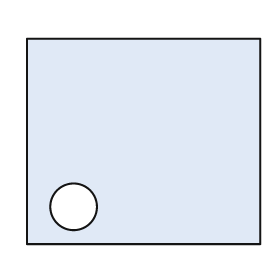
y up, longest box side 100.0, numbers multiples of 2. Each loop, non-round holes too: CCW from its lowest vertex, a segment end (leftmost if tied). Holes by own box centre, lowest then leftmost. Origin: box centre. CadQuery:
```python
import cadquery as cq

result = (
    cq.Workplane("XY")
    .moveTo(-50.0, -44.0)
    .lineTo(50.0, -44.0)
    .lineTo(50.0, 44.0)
    .lineTo(-50.0, 44.0)
    .close()
    .moveTo(-30.0, -28.0)
    .circle(10.0)
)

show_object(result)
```